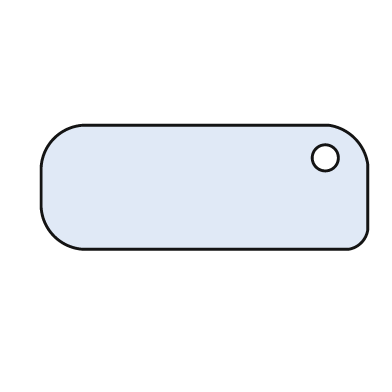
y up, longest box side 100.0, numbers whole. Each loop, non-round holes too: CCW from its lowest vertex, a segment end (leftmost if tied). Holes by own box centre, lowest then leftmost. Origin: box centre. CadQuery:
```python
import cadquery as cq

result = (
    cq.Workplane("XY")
    .moveTo(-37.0, -19.0)
    .lineTo(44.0, -19.0)
    .threePointArc((48.0, -17.0), (50.0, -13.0))
    .lineTo(50.0, 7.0)
    .threePointArc((46.0, 15.0), (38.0, 19.0))
    .lineTo(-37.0, 19.0)
    .threePointArc((-46.0, 15.0), (-50.0, 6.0))
    .lineTo(-50.0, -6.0)
    .threePointArc((-46.0, -15.0), (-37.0, -19.0))
    .close()
    .moveTo(37.0, 9.0)
    .circle(4.0)
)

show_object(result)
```